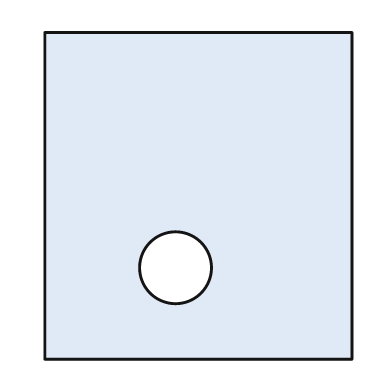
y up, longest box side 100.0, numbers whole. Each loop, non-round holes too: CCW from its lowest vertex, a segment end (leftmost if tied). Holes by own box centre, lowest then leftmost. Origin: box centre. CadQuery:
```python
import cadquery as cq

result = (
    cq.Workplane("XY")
    .moveTo(-47.0, -50.0)
    .lineTo(47.0, -50.0)
    .lineTo(47.0, 50.0)
    .lineTo(-47.0, 50.0)
    .close()
    .moveTo(-7.0, -22.0)
    .circle(11.0)
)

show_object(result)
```